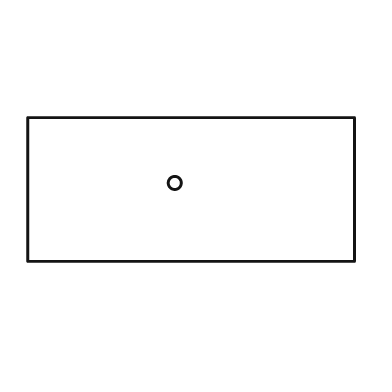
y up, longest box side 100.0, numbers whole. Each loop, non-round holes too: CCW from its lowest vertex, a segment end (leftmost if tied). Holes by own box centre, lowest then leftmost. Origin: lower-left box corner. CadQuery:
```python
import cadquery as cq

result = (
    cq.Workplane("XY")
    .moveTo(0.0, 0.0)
    .lineTo(100.0, 0.0)
    .lineTo(100.0, 44.0)
    .lineTo(0.0, 44.0)
    .close()
    .moveTo(45.0, 24.0)
    .circle(2.0)
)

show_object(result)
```